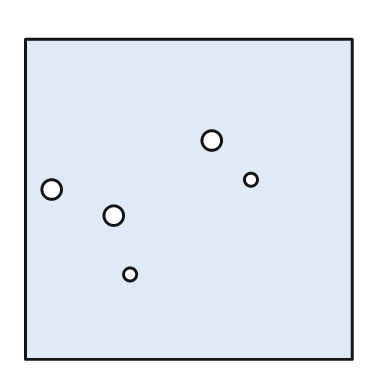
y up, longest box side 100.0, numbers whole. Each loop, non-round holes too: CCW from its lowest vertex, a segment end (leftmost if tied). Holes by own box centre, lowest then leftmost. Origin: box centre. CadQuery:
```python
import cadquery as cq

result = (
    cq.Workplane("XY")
    .moveTo(-50.0, -49.0)
    .lineTo(50.0, -49.0)
    .lineTo(50.0, 49.0)
    .lineTo(-50.0, 49.0)
    .close()
    .moveTo(-18.0, -23.0)
    .circle(2.0)
    .moveTo(-23.0, -5.0)
    .circle(3.0)
    .moveTo(-42.0, 3.0)
    .circle(3.0)
    .moveTo(19.0, 6.0)
    .circle(2.0)
    .moveTo(7.0, 18.0)
    .circle(3.0)
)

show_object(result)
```